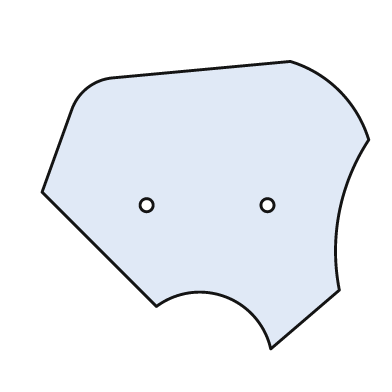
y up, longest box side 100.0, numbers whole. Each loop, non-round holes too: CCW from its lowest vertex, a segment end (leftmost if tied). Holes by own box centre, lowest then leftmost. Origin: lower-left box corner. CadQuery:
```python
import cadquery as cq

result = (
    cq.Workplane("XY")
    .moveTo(70.0, 0.0)
    .lineTo(91.0, 18.0)
    .threePointArc((91.0, 42.0), (100.0, 64.0))
    .threePointArc((91.0, 79.0), (76.0, 88.0))
    .lineTo(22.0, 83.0)
    .threePointArc((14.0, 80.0), (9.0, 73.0))
    .lineTo(0.0, 48.0)
    .lineTo(35.0, 13.0)
    .threePointArc((56.0, 16.0), (70.0, 0.0))
    .close()
    .moveTo(32.0, 44.0)
    .circle(2.0)
    .moveTo(69.0, 44.0)
    .circle(2.0)
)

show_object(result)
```